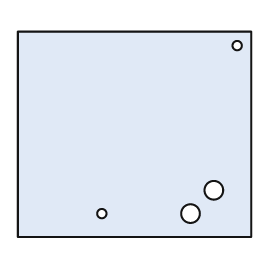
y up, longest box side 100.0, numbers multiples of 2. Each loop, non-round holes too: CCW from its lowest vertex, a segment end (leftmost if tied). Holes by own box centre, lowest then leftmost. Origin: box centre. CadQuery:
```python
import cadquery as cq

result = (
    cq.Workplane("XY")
    .moveTo(-50.0, -44.0)
    .lineTo(50.0, -44.0)
    .lineTo(50.0, 44.0)
    .lineTo(-50.0, 44.0)
    .close()
    .moveTo(-14.0, -34.0)
    .circle(2.0)
    .moveTo(24.0, -34.0)
    .circle(4.0)
    .moveTo(34.0, -24.0)
    .circle(4.0)
    .moveTo(44.0, 38.0)
    .circle(2.0)
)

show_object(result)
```